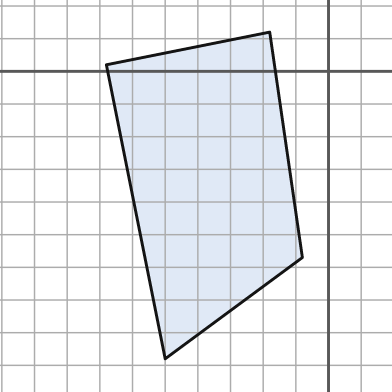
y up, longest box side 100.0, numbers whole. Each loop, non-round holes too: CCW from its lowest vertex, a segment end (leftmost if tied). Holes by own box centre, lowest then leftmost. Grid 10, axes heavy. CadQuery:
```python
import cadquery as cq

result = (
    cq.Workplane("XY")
    .moveTo(-50.0, -88.0)
    .lineTo(-8.0, -57.0)
    .lineTo(-18.0, 12.0)
    .lineTo(-68.0, 2.0)
    .close()
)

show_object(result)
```